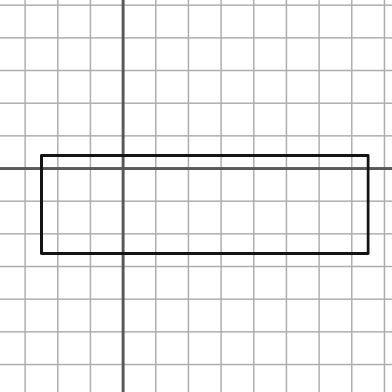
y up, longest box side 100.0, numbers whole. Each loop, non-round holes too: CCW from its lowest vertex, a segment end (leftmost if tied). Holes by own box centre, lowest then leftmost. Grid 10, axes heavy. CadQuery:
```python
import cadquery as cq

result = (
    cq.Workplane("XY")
    .moveTo(-25.0, -26.0)
    .lineTo(75.0, -26.0)
    .lineTo(75.0, 4.0)
    .lineTo(-25.0, 4.0)
    .close()
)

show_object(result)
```